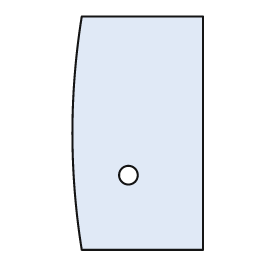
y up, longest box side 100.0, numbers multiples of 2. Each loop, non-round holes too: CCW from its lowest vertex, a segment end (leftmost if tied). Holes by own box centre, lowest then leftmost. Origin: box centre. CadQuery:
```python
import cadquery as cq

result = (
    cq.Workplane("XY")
    .moveTo(-24.0, -50.0)
    .lineTo(28.0, -50.0)
    .lineTo(28.0, 50.0)
    .lineTo(-24.0, 50.0)
    .threePointArc((-28.0, 0.0), (-24.0, -50.0))
    .close()
    .moveTo(-4.0, -18.0)
    .circle(4.0)
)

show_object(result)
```